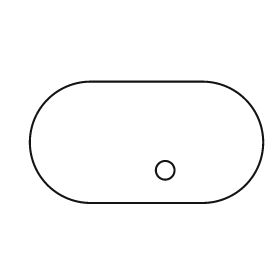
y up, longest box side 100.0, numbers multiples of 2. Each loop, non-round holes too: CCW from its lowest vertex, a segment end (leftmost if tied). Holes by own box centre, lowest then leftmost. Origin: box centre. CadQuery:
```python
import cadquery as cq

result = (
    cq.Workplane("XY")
    .moveTo(-24.0, -26.0)
    .lineTo(24.0, -26.0)
    .threePointArc((50.0, 0.0), (24.0, 26.0))
    .lineTo(-24.0, 26.0)
    .threePointArc((-50.0, 0.0), (-24.0, -26.0))
    .close()
    .moveTo(8.0, -12.0)
    .circle(4.0)
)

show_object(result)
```